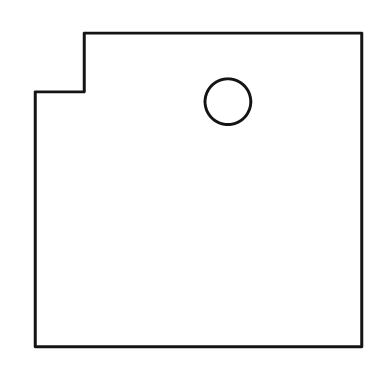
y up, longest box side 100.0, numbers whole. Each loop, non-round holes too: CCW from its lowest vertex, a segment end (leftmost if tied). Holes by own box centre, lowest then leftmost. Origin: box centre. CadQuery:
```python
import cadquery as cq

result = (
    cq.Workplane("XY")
    .moveTo(-50.0, -48.0)
    .lineTo(50.0, -48.0)
    .lineTo(50.0, 48.0)
    .lineTo(-35.0, 48.0)
    .lineTo(-35.0, 30.0)
    .lineTo(-50.0, 30.0)
    .close()
    .moveTo(9.0, 27.0)
    .circle(7.0)
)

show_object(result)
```